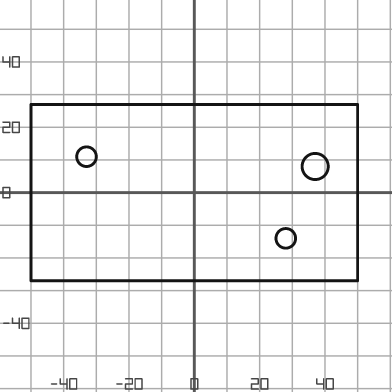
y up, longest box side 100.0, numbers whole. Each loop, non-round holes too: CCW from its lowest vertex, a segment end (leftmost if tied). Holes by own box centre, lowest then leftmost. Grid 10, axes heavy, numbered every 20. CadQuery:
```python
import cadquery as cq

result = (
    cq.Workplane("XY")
    .moveTo(-50.0, -27.0)
    .lineTo(50.0, -27.0)
    .lineTo(50.0, 27.0)
    .lineTo(-50.0, 27.0)
    .close()
    .moveTo(28.0, -14.0)
    .circle(3.0)
    .moveTo(37.0, 8.0)
    .circle(4.0)
    .moveTo(-33.0, 11.0)
    .circle(3.0)
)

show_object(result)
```